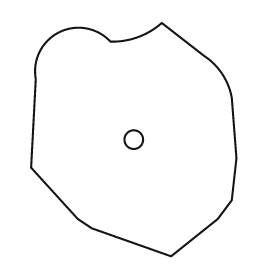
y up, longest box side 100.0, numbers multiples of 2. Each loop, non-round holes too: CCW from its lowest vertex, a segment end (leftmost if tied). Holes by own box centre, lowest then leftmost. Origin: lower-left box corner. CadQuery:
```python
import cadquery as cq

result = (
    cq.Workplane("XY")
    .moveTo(60.0, 0.0)
    .lineTo(80.0, 16.0)
    .lineTo(86.0, 24.0)
    .lineTo(88.0, 42.0)
    .lineTo(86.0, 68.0)
    .threePointArc((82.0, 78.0), (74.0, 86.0))
    .lineTo(56.0, 100.0)
    .threePointArc((46.0, 94.0), (34.0, 92.0))
    .threePointArc((12.0, 96.0), (2.0, 76.0))
    .lineTo(0.0, 38.0)
    .lineTo(20.0, 16.0)
    .lineTo(26.0, 12.0)
    .close()
    .moveTo(44.0, 50.0)
    .circle(4.0)
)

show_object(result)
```